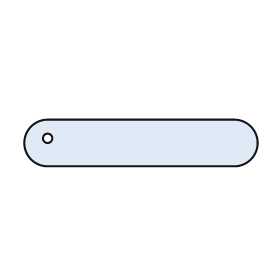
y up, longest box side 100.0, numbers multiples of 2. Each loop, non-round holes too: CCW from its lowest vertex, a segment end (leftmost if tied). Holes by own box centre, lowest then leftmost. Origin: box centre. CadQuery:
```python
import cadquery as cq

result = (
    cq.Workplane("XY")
    .moveTo(-40.0, -10.0)
    .lineTo(40.0, -10.0)
    .threePointArc((50.0, 0.0), (40.0, 10.0))
    .lineTo(-40.0, 10.0)
    .threePointArc((-50.0, 0.0), (-40.0, -10.0))
    .close()
    .moveTo(-40.0, 2.0)
    .circle(2.0)
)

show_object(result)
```